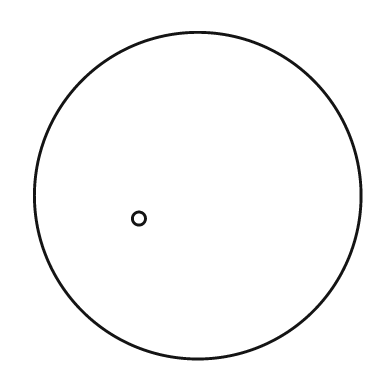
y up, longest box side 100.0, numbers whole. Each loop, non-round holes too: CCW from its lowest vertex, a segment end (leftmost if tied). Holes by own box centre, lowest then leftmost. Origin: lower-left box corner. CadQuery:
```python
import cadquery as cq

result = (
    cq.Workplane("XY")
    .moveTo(50.0, 50.0)
    .circle(50.0)
    .moveTo(32.0, 43.0)
    .circle(2.0)
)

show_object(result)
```